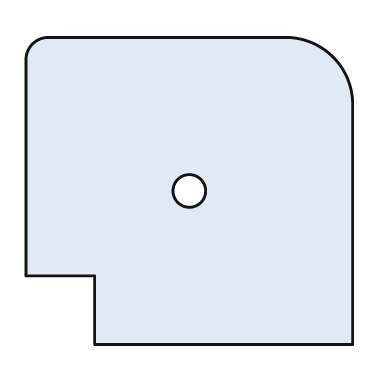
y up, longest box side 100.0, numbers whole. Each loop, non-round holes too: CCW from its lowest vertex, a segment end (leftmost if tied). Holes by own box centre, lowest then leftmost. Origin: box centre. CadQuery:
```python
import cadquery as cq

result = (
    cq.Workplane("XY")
    .moveTo(-29.0, -47.0)
    .lineTo(50.0, -47.0)
    .lineTo(50.0, 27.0)
    .threePointArc((44.0, 41.0), (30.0, 47.0))
    .lineTo(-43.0, 47.0)
    .threePointArc((-48.0, 45.0), (-50.0, 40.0))
    .lineTo(-50.0, -26.0)
    .lineTo(-29.0, -26.0)
    .close()
    .moveTo(0.0, 0.0)
    .circle(5.0)
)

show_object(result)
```